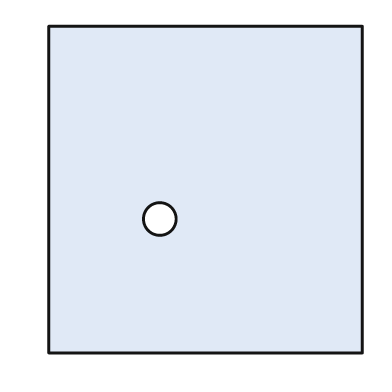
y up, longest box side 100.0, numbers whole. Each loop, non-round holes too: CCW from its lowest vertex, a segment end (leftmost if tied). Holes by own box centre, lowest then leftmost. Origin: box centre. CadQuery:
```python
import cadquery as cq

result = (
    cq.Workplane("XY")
    .moveTo(-48.0, -50.0)
    .lineTo(48.0, -50.0)
    .lineTo(48.0, 50.0)
    .lineTo(-48.0, 50.0)
    .close()
    .moveTo(-14.0, -9.0)
    .circle(5.0)
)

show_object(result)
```